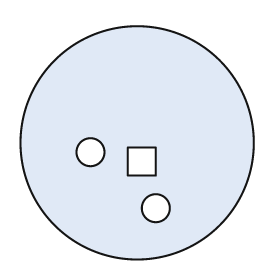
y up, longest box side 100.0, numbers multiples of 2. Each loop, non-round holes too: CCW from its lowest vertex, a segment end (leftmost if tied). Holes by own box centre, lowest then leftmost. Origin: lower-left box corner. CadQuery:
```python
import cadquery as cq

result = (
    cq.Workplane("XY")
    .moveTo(50.0, 50.0)
    .circle(50.0)
    .moveTo(58.0, 22.0)
    .circle(6.0)
    .moveTo(46.0, 36.0)
    .lineTo(58.0, 36.0)
    .lineTo(58.0, 48.0)
    .lineTo(46.0, 48.0)
    .close()
    .moveTo(30.0, 46.0)
    .circle(6.0)
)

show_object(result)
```